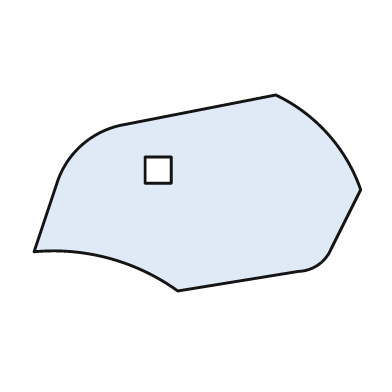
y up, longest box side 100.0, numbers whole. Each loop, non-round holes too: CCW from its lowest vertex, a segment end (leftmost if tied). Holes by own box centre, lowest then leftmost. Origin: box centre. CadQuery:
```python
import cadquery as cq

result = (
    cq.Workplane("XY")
    .moveTo(-6.0, -30.0)
    .lineTo(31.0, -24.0)
    .threePointArc((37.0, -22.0), (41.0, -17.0))
    .lineTo(50.0, 1.0)
    .threePointArc((40.0, 18.0), (24.0, 30.0))
    .lineTo(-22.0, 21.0)
    .threePointArc((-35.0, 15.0), (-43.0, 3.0))
    .lineTo(-50.0, -18.0)
    .threePointArc((-27.0, -20.0), (-6.0, -30.0))
    .close()
    .moveTo(-16.0, 3.0)
    .lineTo(-8.0, 3.0)
    .lineTo(-8.0, 11.0)
    .lineTo(-16.0, 11.0)
    .close()
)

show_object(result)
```